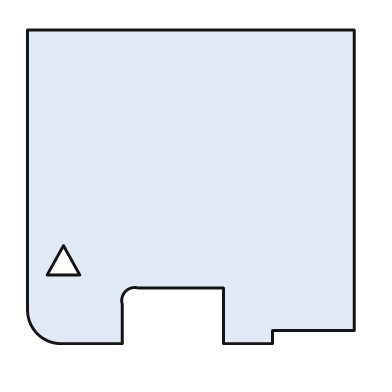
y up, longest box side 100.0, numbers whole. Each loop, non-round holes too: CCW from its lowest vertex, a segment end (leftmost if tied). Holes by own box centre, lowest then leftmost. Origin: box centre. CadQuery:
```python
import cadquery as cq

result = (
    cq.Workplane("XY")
    .moveTo(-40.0, -48.0)
    .lineTo(-21.0, -48.0)
    .lineTo(-21.0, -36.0)
    .threePointArc((-20.0, -32.0), (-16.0, -31.0))
    .lineTo(10.0, -31.0)
    .lineTo(10.0, -48.0)
    .lineTo(25.0, -48.0)
    .lineTo(25.0, -44.0)
    .lineTo(50.0, -44.0)
    .lineTo(50.0, 48.0)
    .lineTo(-50.0, 48.0)
    .lineTo(-50.0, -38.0)
    .threePointArc((-47.0, -45.0), (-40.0, -48.0))
    .close()
    .moveTo(-44.0, -27.0)
    .lineTo(-34.0, -27.0)
    .lineTo(-39.0, -18.0)
    .close()
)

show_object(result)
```